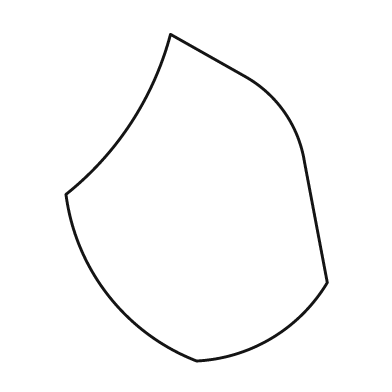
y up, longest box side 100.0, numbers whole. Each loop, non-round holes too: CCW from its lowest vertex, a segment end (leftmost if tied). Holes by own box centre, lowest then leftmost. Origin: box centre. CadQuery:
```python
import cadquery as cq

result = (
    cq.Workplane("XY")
    .moveTo(0.0, -50.0)
    .threePointArc((23.0, -43.0), (40.0, -26.0))
    .lineTo(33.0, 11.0)
    .threePointArc((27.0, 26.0), (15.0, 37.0))
    .lineTo(-8.0, 50.0)
    .threePointArc((-20.0, 23.0), (-40.0, 1.0))
    .threePointArc((-27.0, -30.0), (0.0, -50.0))
    .close()
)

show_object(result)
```